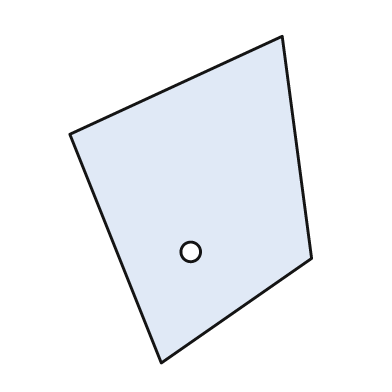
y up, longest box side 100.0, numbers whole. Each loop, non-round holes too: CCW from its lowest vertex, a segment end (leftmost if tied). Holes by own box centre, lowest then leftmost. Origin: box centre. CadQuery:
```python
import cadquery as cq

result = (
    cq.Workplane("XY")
    .moveTo(-9.0, -50.0)
    .lineTo(37.0, -18.0)
    .lineTo(28.0, 50.0)
    .lineTo(-37.0, 20.0)
    .close()
    .moveTo(0.0, -16.0)
    .circle(3.0)
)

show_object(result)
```